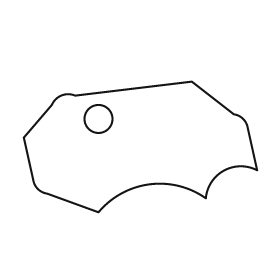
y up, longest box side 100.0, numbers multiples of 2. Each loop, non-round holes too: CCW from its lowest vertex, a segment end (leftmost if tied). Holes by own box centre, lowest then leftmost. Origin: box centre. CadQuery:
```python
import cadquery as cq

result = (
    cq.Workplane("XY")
    .moveTo(-18.0, -28.0)
    .threePointArc((4.0, -16.0), (28.0, -22.0))
    .threePointArc((36.0, -10.0), (50.0, -10.0))
    .lineTo(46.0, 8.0)
    .threePointArc((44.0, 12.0), (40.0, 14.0))
    .lineTo(22.0, 28.0)
    .lineTo(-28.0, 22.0)
    .threePointArc((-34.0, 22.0), (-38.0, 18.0))
    .lineTo(-50.0, 4.0)
    .lineTo(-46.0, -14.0)
    .threePointArc((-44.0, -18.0), (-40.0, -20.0))
    .close()
    .moveTo(-18.0, 12.0)
    .circle(6.0)
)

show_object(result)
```